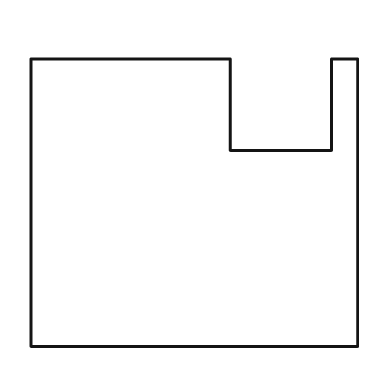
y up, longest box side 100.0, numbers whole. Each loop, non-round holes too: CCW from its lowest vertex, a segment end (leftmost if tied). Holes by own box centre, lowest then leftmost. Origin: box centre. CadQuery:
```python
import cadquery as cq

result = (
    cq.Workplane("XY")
    .moveTo(-50.0, -44.0)
    .lineTo(50.0, -44.0)
    .lineTo(50.0, 44.0)
    .lineTo(42.0, 44.0)
    .lineTo(42.0, 16.0)
    .lineTo(11.0, 16.0)
    .lineTo(11.0, 44.0)
    .lineTo(-50.0, 44.0)
    .close()
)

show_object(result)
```